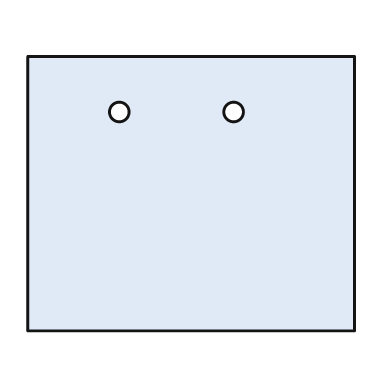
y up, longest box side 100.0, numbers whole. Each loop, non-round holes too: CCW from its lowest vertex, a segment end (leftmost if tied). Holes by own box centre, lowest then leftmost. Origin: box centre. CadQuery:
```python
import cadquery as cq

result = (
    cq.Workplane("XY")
    .moveTo(-50.0, -42.0)
    .lineTo(50.0, -42.0)
    .lineTo(50.0, 42.0)
    .lineTo(-50.0, 42.0)
    .close()
    .moveTo(-22.0, 25.0)
    .circle(3.0)
    .moveTo(13.0, 25.0)
    .circle(3.0)
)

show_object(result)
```